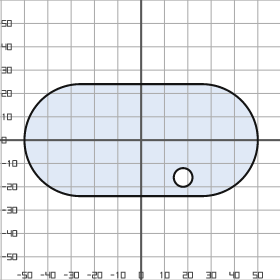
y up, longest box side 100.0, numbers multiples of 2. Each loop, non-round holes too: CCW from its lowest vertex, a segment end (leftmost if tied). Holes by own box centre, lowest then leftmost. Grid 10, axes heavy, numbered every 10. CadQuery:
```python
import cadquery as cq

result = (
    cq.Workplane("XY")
    .moveTo(-26.0, -24.0)
    .lineTo(26.0, -24.0)
    .threePointArc((50.0, 0.0), (26.0, 24.0))
    .lineTo(-26.0, 24.0)
    .threePointArc((-50.0, 0.0), (-26.0, -24.0))
    .close()
    .moveTo(18.0, -16.0)
    .circle(4.0)
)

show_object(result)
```